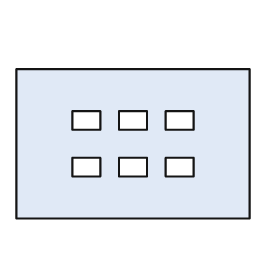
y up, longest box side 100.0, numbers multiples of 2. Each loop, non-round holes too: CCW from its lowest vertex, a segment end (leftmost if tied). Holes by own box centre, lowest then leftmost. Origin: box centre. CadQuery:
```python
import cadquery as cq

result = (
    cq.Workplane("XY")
    .moveTo(-50.0, -32.0)
    .lineTo(50.0, -32.0)
    .lineTo(50.0, 32.0)
    .lineTo(-50.0, 32.0)
    .close()
    .moveTo(-26.0, -14.0)
    .lineTo(-14.0, -14.0)
    .lineTo(-14.0, -6.0)
    .lineTo(-26.0, -6.0)
    .close()
    .moveTo(-6.0, -14.0)
    .lineTo(6.0, -14.0)
    .lineTo(6.0, -6.0)
    .lineTo(-6.0, -6.0)
    .close()
    .moveTo(14.0, -14.0)
    .lineTo(26.0, -14.0)
    .lineTo(26.0, -6.0)
    .lineTo(14.0, -6.0)
    .close()
    .moveTo(-26.0, 6.0)
    .lineTo(-14.0, 6.0)
    .lineTo(-14.0, 14.0)
    .lineTo(-26.0, 14.0)
    .close()
    .moveTo(-6.0, 6.0)
    .lineTo(6.0, 6.0)
    .lineTo(6.0, 14.0)
    .lineTo(-6.0, 14.0)
    .close()
    .moveTo(14.0, 6.0)
    .lineTo(26.0, 6.0)
    .lineTo(26.0, 14.0)
    .lineTo(14.0, 14.0)
    .close()
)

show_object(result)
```